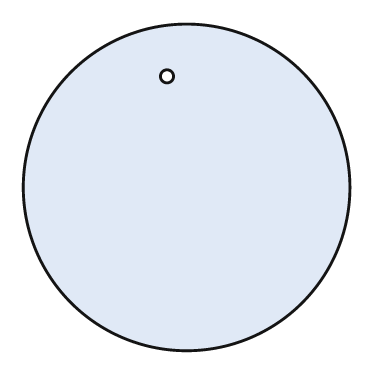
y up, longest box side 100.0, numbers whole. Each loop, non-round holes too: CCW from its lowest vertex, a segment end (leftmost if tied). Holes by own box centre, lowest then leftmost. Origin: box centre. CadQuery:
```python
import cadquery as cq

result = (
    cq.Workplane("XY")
    .moveTo(0.0, 0.0)
    .circle(50.0)
    .moveTo(-6.0, 34.0)
    .circle(2.0)
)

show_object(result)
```